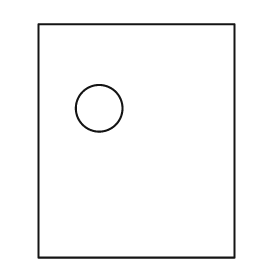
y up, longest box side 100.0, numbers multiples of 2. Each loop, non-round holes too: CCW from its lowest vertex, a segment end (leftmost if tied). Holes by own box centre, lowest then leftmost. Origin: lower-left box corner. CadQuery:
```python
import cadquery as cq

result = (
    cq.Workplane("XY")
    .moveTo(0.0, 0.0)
    .lineTo(84.0, 0.0)
    .lineTo(84.0, 100.0)
    .lineTo(0.0, 100.0)
    .close()
    .moveTo(26.0, 64.0)
    .circle(10.0)
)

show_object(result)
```